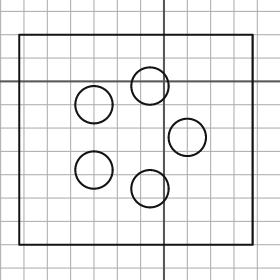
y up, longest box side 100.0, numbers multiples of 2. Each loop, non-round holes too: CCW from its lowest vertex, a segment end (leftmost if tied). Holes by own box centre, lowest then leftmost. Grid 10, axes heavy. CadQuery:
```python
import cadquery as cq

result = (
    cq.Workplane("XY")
    .moveTo(-62.0, -70.0)
    .lineTo(38.0, -70.0)
    .lineTo(38.0, 20.0)
    .lineTo(-62.0, 20.0)
    .close()
    .moveTo(-6.0, -46.0)
    .circle(8.0)
    .moveTo(-30.0, -38.0)
    .circle(8.0)
    .moveTo(10.0, -24.0)
    .circle(8.0)
    .moveTo(-30.0, -10.0)
    .circle(8.0)
    .moveTo(-6.0, -2.0)
    .circle(8.0)
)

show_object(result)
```